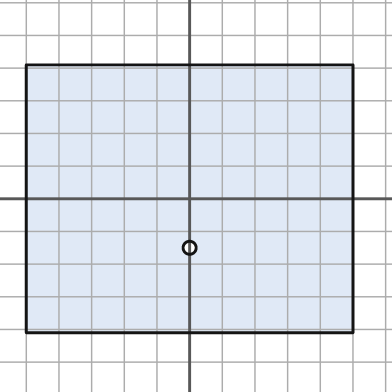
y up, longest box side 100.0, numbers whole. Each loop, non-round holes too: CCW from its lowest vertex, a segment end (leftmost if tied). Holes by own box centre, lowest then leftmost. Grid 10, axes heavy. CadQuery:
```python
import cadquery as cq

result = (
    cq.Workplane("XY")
    .moveTo(-50.0, -41.0)
    .lineTo(50.0, -41.0)
    .lineTo(50.0, 41.0)
    .lineTo(-50.0, 41.0)
    .close()
    .moveTo(0.0, -15.0)
    .circle(2.0)
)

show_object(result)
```